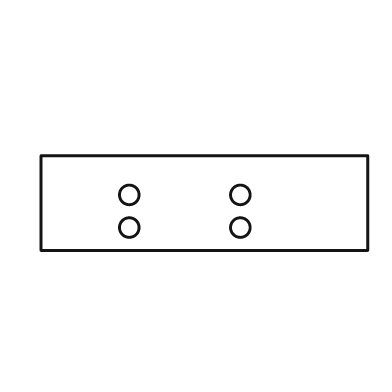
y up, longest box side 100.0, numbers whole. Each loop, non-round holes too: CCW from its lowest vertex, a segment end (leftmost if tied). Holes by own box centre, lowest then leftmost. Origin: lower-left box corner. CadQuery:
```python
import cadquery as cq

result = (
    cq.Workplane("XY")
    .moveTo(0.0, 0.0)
    .lineTo(100.0, 0.0)
    .lineTo(100.0, 29.0)
    .lineTo(0.0, 29.0)
    .close()
    .moveTo(27.0, 7.0)
    .circle(3.0)
    .moveTo(61.0, 7.0)
    .circle(3.0)
    .moveTo(27.0, 17.0)
    .circle(3.0)
    .moveTo(61.0, 17.0)
    .circle(3.0)
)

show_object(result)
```